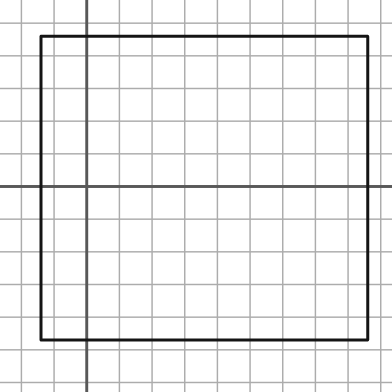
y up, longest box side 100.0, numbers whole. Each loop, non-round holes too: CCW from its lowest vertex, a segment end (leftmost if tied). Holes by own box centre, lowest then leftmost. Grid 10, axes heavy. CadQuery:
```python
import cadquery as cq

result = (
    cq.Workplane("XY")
    .moveTo(-14.0, -47.0)
    .lineTo(86.0, -47.0)
    .lineTo(86.0, 46.0)
    .lineTo(-14.0, 46.0)
    .close()
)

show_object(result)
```